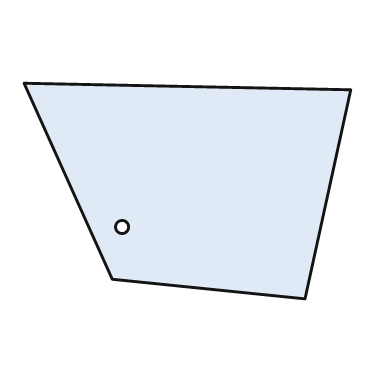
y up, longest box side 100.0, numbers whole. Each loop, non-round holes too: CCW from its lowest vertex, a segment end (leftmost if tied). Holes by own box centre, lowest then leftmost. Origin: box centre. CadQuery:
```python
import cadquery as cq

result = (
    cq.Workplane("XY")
    .moveTo(36.0, -33.0)
    .lineTo(50.0, 31.0)
    .lineTo(-50.0, 33.0)
    .lineTo(-23.0, -27.0)
    .close()
    .moveTo(-20.0, -11.0)
    .circle(2.0)
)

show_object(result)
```